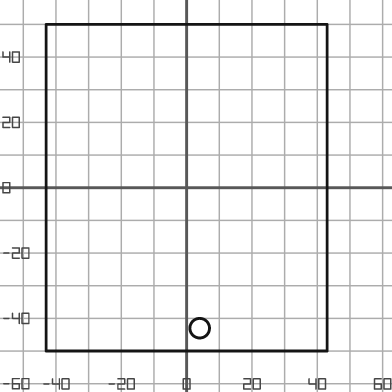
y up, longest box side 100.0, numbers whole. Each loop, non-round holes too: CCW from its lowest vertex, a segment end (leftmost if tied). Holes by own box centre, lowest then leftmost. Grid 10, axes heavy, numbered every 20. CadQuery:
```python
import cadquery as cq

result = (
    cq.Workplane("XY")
    .moveTo(-43.0, -50.0)
    .lineTo(43.0, -50.0)
    .lineTo(43.0, 50.0)
    .lineTo(-43.0, 50.0)
    .close()
    .moveTo(4.0, -43.0)
    .circle(3.0)
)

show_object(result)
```